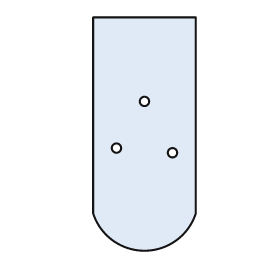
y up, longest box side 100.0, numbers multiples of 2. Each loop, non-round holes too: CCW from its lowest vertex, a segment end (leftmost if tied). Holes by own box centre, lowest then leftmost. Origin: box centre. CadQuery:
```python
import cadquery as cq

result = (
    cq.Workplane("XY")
    .moveTo(-22.0, -34.0)
    .threePointArc((0.0, -50.0), (22.0, -34.0))
    .lineTo(22.0, 50.0)
    .lineTo(-22.0, 50.0)
    .close()
    .moveTo(12.0, -8.0)
    .circle(2.0)
    .moveTo(-12.0, -6.0)
    .circle(2.0)
    .moveTo(0.0, 14.0)
    .circle(2.0)
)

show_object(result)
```